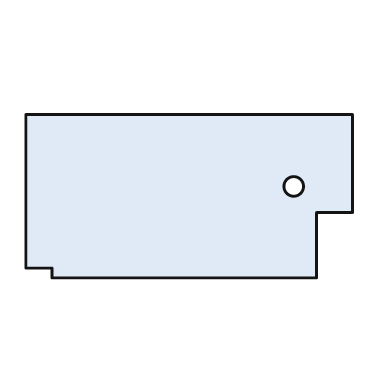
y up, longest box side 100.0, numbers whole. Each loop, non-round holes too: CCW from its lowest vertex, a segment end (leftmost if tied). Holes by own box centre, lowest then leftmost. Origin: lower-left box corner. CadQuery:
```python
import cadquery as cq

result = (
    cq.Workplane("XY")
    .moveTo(8.0, 0.0)
    .lineTo(89.0, 0.0)
    .lineTo(89.0, 20.0)
    .lineTo(100.0, 20.0)
    .lineTo(100.0, 50.0)
    .lineTo(0.0, 50.0)
    .lineTo(0.0, 3.0)
    .lineTo(8.0, 3.0)
    .close()
    .moveTo(82.0, 28.0)
    .circle(3.0)
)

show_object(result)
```